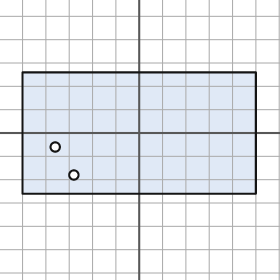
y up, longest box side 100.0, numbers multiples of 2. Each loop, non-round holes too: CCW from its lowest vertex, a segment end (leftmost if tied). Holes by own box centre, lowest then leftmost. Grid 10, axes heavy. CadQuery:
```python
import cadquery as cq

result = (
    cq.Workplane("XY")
    .moveTo(-50.0, -26.0)
    .lineTo(50.0, -26.0)
    .lineTo(50.0, 26.0)
    .lineTo(-50.0, 26.0)
    .close()
    .moveTo(-28.0, -18.0)
    .circle(2.0)
    .moveTo(-36.0, -6.0)
    .circle(2.0)
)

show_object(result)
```